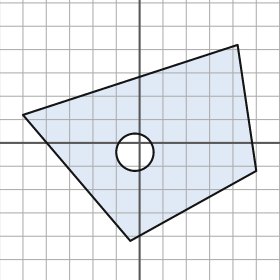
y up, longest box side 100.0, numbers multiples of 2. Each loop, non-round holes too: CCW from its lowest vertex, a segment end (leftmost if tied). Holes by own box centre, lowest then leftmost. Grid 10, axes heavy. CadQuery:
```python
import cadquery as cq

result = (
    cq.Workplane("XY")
    .moveTo(-4.0, -42.0)
    .lineTo(50.0, -12.0)
    .lineTo(42.0, 42.0)
    .lineTo(-50.0, 12.0)
    .close()
    .moveTo(-2.0, -4.0)
    .circle(8.0)
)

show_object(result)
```